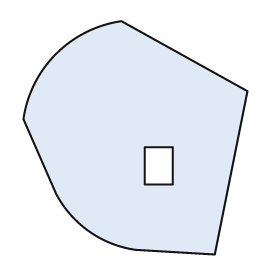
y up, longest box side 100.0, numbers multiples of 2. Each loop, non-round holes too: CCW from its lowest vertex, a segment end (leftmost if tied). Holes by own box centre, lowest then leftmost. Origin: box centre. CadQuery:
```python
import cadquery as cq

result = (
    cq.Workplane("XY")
    .moveTo(34.0, -50.0)
    .lineTo(48.0, 20.0)
    .lineTo(-6.0, 50.0)
    .threePointArc((-34.0, 36.0), (-48.0, 8.0))
    .lineTo(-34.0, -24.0)
    .threePointArc((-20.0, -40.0), (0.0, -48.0))
    .close()
    .moveTo(4.0, -20.0)
    .lineTo(16.0, -20.0)
    .lineTo(16.0, -4.0)
    .lineTo(4.0, -4.0)
    .close()
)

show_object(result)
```